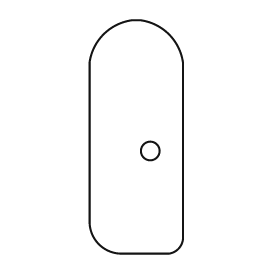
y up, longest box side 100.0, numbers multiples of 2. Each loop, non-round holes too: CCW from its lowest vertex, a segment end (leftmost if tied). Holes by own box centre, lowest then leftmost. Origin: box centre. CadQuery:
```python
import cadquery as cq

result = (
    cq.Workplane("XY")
    .moveTo(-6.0, -50.0)
    .lineTo(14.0, -50.0)
    .threePointArc((18.0, -48.0), (20.0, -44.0))
    .lineTo(20.0, 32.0)
    .threePointArc((14.0, 44.0), (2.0, 50.0))
    .lineTo(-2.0, 50.0)
    .threePointArc((-14.0, 44.0), (-20.0, 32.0))
    .lineTo(-20.0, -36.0)
    .threePointArc((-16.0, -46.0), (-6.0, -50.0))
    .close()
    .moveTo(6.0, -6.0)
    .circle(4.0)
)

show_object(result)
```